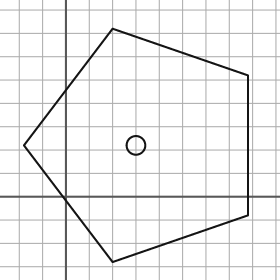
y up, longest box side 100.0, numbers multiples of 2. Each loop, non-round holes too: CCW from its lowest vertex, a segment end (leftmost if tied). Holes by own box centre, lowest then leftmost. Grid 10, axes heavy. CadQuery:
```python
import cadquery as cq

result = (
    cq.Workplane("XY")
    .moveTo(20.0, -28.0)
    .lineTo(78.0, -8.0)
    .lineTo(78.0, 52.0)
    .lineTo(20.0, 72.0)
    .lineTo(-18.0, 22.0)
    .close()
    .moveTo(30.0, 22.0)
    .circle(4.0)
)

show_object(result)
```